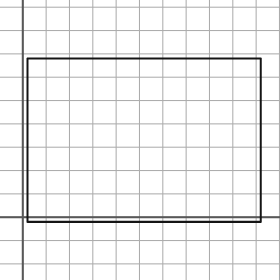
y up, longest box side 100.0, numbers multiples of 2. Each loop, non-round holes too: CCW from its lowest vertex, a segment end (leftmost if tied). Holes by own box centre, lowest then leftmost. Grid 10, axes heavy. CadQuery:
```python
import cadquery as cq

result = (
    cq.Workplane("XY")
    .moveTo(2.0, -2.0)
    .lineTo(102.0, -2.0)
    .lineTo(102.0, 68.0)
    .lineTo(2.0, 68.0)
    .close()
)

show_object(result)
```